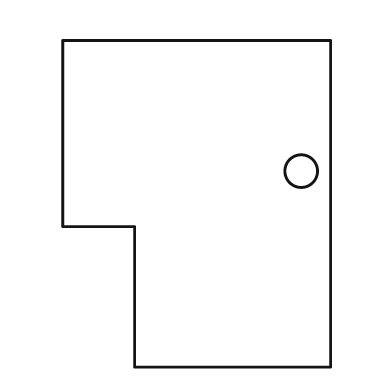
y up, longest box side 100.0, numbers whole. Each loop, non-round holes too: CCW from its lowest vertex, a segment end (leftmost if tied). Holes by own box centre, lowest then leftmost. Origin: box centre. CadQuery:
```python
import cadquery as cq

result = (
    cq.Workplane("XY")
    .moveTo(-19.0, -50.0)
    .lineTo(41.0, -50.0)
    .lineTo(41.0, 50.0)
    .lineTo(-41.0, 50.0)
    .lineTo(-41.0, -7.0)
    .lineTo(-19.0, -7.0)
    .close()
    .moveTo(32.0, 10.0)
    .circle(5.0)
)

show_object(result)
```